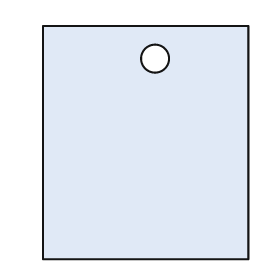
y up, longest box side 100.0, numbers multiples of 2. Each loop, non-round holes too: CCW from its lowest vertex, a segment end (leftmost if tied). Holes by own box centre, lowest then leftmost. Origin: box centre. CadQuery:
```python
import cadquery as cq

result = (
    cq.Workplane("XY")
    .moveTo(-44.0, -50.0)
    .lineTo(44.0, -50.0)
    .lineTo(44.0, 50.0)
    .lineTo(-44.0, 50.0)
    .close()
    .moveTo(4.0, 36.0)
    .circle(6.0)
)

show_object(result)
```